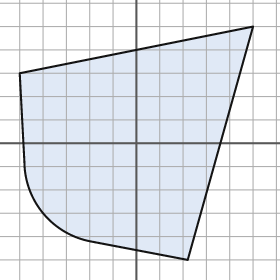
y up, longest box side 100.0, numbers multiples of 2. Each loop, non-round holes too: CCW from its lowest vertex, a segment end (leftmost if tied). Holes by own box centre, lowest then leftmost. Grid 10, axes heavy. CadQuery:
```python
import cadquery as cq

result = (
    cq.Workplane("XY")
    .moveTo(22.0, -50.0)
    .lineTo(50.0, 50.0)
    .lineTo(-50.0, 30.0)
    .lineTo(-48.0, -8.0)
    .threePointArc((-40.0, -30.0), (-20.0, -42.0))
    .close()
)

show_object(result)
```